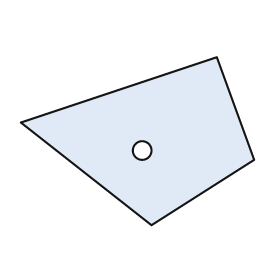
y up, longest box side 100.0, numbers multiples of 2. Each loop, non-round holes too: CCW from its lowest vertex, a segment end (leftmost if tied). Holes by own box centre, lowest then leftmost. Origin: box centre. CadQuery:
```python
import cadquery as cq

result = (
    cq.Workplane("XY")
    .moveTo(6.0, -36.0)
    .lineTo(50.0, -8.0)
    .lineTo(34.0, 36.0)
    .lineTo(-50.0, 8.0)
    .close()
    .moveTo(2.0, -4.0)
    .circle(4.0)
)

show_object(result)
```